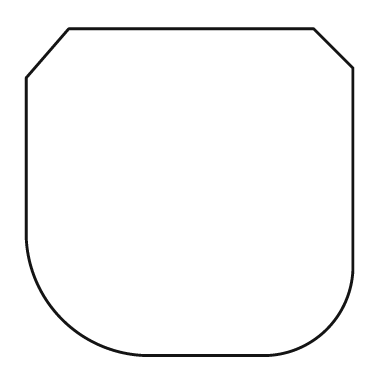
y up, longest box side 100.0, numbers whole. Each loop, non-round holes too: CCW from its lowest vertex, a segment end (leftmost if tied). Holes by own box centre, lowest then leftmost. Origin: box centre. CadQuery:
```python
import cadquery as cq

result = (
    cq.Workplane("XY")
    .moveTo(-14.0, -50.0)
    .lineTo(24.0, -50.0)
    .threePointArc((42.0, -42.0), (50.0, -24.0))
    .lineTo(50.0, 38.0)
    .lineTo(38.0, 50.0)
    .lineTo(-37.0, 50.0)
    .lineTo(-50.0, 35.0)
    .lineTo(-50.0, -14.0)
    .threePointArc((-39.0, -39.0), (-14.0, -50.0))
    .close()
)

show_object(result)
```